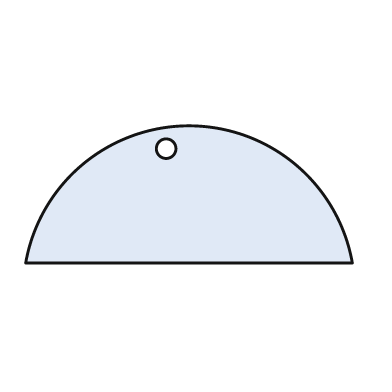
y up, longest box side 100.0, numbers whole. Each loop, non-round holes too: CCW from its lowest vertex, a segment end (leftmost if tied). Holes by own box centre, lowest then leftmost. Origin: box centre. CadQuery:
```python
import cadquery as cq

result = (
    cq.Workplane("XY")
    .moveTo(-50.0, -21.0)
    .lineTo(50.0, -21.0)
    .threePointArc((0.0, 21.0), (-50.0, -21.0))
    .close()
    .moveTo(-7.0, 14.0)
    .circle(3.0)
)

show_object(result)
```